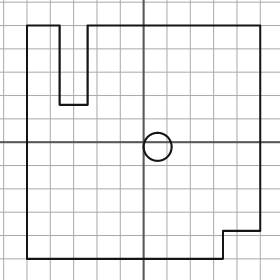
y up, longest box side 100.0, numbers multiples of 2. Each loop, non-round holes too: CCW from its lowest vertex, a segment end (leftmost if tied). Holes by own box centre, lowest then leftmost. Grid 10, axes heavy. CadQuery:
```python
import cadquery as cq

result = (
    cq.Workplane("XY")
    .moveTo(-50.0, -50.0)
    .lineTo(34.0, -50.0)
    .lineTo(34.0, -38.0)
    .lineTo(50.0, -38.0)
    .lineTo(50.0, 50.0)
    .lineTo(-24.0, 50.0)
    .lineTo(-24.0, 16.0)
    .lineTo(-36.0, 16.0)
    .lineTo(-36.0, 50.0)
    .lineTo(-50.0, 50.0)
    .close()
    .moveTo(6.0, -2.0)
    .circle(6.0)
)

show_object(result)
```